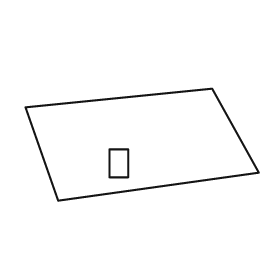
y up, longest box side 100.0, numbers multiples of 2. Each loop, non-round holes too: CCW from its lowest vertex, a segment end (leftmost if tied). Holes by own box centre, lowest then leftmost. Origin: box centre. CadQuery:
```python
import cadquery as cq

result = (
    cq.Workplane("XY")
    .moveTo(-36.0, -24.0)
    .lineTo(50.0, -12.0)
    .lineTo(30.0, 24.0)
    .lineTo(-50.0, 16.0)
    .close()
    .moveTo(-14.0, -14.0)
    .lineTo(-6.0, -14.0)
    .lineTo(-6.0, -2.0)
    .lineTo(-14.0, -2.0)
    .close()
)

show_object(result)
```